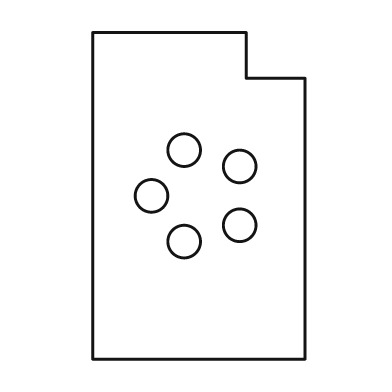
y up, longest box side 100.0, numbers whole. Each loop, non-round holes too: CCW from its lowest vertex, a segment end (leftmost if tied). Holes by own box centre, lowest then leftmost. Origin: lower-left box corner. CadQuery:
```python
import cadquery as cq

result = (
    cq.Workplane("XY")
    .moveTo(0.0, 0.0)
    .lineTo(65.0, 0.0)
    .lineTo(65.0, 86.0)
    .lineTo(47.0, 86.0)
    .lineTo(47.0, 100.0)
    .lineTo(0.0, 100.0)
    .close()
    .moveTo(28.0, 36.0)
    .circle(5.0)
    .moveTo(45.0, 41.0)
    .circle(5.0)
    .moveTo(18.0, 50.0)
    .circle(5.0)
    .moveTo(45.0, 59.0)
    .circle(5.0)
    .moveTo(28.0, 64.0)
    .circle(5.0)
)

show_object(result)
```